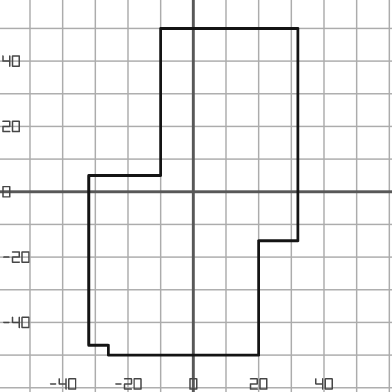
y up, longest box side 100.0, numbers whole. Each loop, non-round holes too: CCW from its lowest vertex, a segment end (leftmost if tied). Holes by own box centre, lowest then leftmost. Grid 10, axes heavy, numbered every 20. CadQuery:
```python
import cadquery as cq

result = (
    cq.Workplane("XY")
    .moveTo(-26.0, -50.0)
    .lineTo(20.0, -50.0)
    .lineTo(20.0, -15.0)
    .lineTo(32.0, -15.0)
    .lineTo(32.0, 50.0)
    .lineTo(-10.0, 50.0)
    .lineTo(-10.0, 5.0)
    .lineTo(-32.0, 5.0)
    .lineTo(-32.0, -47.0)
    .lineTo(-26.0, -47.0)
    .close()
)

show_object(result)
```